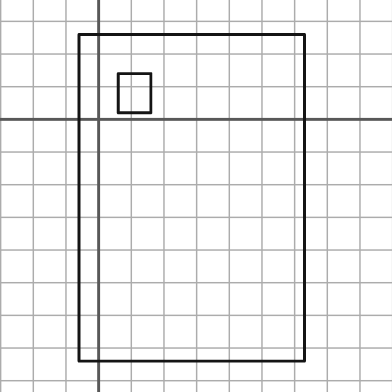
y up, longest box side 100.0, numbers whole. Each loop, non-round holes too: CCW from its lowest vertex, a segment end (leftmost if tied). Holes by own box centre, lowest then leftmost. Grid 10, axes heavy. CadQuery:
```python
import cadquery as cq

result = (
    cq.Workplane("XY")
    .moveTo(-6.0, -74.0)
    .lineTo(63.0, -74.0)
    .lineTo(63.0, 26.0)
    .lineTo(-6.0, 26.0)
    .close()
    .moveTo(6.0, 2.0)
    .lineTo(16.0, 2.0)
    .lineTo(16.0, 14.0)
    .lineTo(6.0, 14.0)
    .close()
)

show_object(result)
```